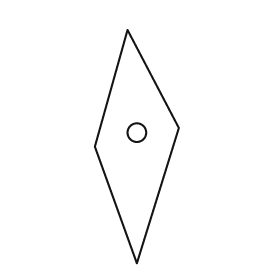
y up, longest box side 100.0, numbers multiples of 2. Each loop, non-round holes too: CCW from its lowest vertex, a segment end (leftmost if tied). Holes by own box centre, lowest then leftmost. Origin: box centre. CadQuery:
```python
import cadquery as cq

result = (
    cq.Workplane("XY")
    .moveTo(0.0, -50.0)
    .lineTo(18.0, 8.0)
    .lineTo(-4.0, 50.0)
    .lineTo(-18.0, 0.0)
    .close()
    .moveTo(0.0, 6.0)
    .circle(4.0)
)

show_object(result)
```